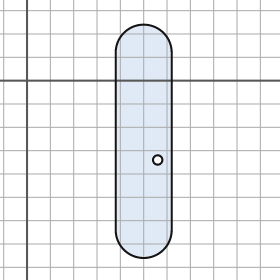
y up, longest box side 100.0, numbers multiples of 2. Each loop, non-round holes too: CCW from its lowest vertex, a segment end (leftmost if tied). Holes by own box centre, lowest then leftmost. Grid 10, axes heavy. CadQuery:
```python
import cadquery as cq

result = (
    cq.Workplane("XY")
    .moveTo(38.0, -64.0)
    .threePointArc((50.0, -76.0), (62.0, -64.0))
    .lineTo(62.0, 12.0)
    .threePointArc((50.0, 24.0), (38.0, 12.0))
    .close()
    .moveTo(56.0, -34.0)
    .circle(2.0)
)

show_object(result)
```